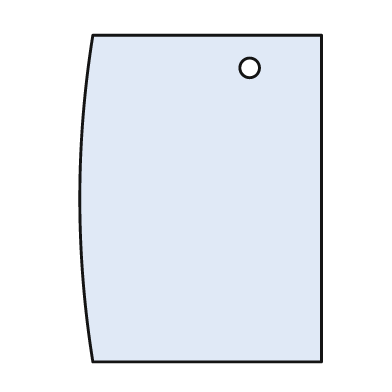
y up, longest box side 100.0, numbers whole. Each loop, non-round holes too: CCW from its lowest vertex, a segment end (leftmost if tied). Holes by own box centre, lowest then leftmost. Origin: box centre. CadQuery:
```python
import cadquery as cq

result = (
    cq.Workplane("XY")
    .moveTo(-33.0, -50.0)
    .lineTo(37.0, -50.0)
    .lineTo(37.0, 50.0)
    .lineTo(-33.0, 50.0)
    .threePointArc((-37.0, 0.0), (-33.0, -50.0))
    .close()
    .moveTo(15.0, 40.0)
    .circle(3.0)
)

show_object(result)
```